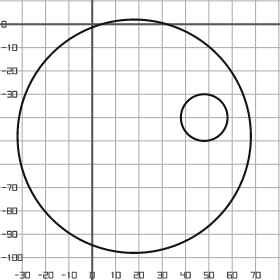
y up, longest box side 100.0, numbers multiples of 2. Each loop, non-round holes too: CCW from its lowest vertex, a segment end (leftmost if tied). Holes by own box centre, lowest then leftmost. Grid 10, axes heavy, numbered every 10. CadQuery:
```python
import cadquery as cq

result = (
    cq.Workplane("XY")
    .moveTo(18.0, -48.0)
    .circle(50.0)
    .moveTo(48.0, -40.0)
    .circle(10.0)
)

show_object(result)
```